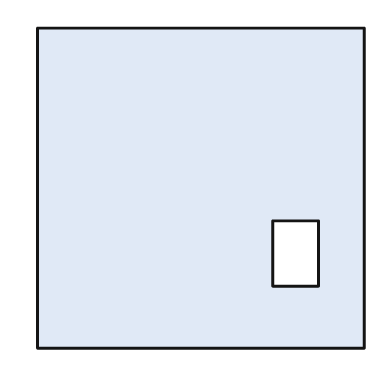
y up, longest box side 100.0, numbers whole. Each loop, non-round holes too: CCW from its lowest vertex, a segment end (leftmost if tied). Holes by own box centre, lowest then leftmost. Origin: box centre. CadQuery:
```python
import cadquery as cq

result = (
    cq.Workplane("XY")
    .moveTo(-50.0, -49.0)
    .lineTo(50.0, -49.0)
    .lineTo(50.0, 49.0)
    .lineTo(-50.0, 49.0)
    .close()
    .moveTo(22.0, -30.0)
    .lineTo(36.0, -30.0)
    .lineTo(36.0, -10.0)
    .lineTo(22.0, -10.0)
    .close()
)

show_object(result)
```